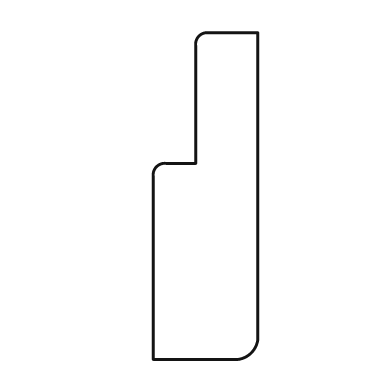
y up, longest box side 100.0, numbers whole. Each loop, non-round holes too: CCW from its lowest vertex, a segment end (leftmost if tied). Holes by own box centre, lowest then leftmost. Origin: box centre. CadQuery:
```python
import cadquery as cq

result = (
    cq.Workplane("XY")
    .moveTo(-16.0, -50.0)
    .lineTo(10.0, -50.0)
    .threePointArc((14.0, -48.0), (16.0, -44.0))
    .lineTo(16.0, 50.0)
    .lineTo(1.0, 50.0)
    .threePointArc((-2.0, 49.0), (-3.0, 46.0))
    .lineTo(-3.0, 10.0)
    .lineTo(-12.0, 10.0)
    .threePointArc((-15.0, 9.0), (-16.0, 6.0))
    .close()
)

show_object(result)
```